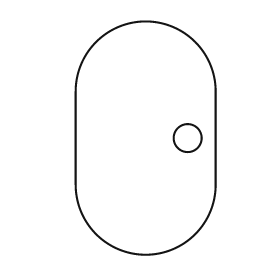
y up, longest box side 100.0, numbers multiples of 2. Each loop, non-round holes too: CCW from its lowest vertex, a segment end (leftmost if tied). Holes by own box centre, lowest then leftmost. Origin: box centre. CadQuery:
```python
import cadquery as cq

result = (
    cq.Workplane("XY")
    .moveTo(-30.0, -20.0)
    .threePointArc((0.0, -50.0), (30.0, -20.0))
    .lineTo(30.0, 20.0)
    .threePointArc((0.0, 50.0), (-30.0, 20.0))
    .close()
    .moveTo(18.0, 0.0)
    .circle(6.0)
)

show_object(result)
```